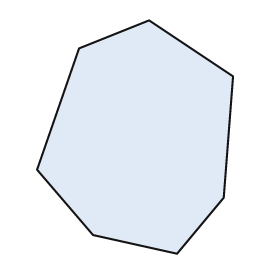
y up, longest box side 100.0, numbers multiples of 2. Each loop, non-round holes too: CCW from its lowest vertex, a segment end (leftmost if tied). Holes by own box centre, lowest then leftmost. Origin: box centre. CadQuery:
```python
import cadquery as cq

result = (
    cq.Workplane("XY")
    .moveTo(18.0, -50.0)
    .lineTo(38.0, -26.0)
    .lineTo(42.0, 26.0)
    .lineTo(6.0, 50.0)
    .lineTo(-24.0, 38.0)
    .lineTo(-42.0, -14.0)
    .lineTo(-18.0, -42.0)
    .close()
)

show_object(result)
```